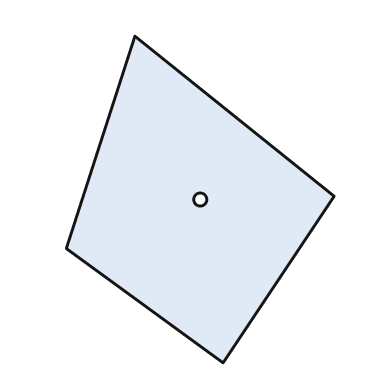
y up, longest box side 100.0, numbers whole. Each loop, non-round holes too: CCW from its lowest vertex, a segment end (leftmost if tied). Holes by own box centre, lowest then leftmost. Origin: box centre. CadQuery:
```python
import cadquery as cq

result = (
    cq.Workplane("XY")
    .moveTo(7.0, -50.0)
    .lineTo(41.0, 1.0)
    .lineTo(-20.0, 50.0)
    .lineTo(-41.0, -15.0)
    .close()
    .moveTo(0.0, 0.0)
    .circle(2.0)
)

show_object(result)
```